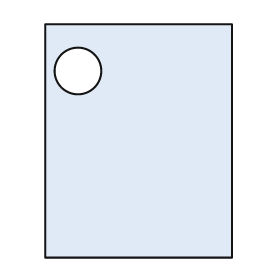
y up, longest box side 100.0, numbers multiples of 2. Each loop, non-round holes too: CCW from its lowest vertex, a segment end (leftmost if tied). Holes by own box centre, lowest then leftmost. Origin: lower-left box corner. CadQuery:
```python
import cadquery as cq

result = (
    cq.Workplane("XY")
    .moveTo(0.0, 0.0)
    .lineTo(80.0, 0.0)
    .lineTo(80.0, 100.0)
    .lineTo(0.0, 100.0)
    .close()
    .moveTo(14.0, 80.0)
    .circle(10.0)
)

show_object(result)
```